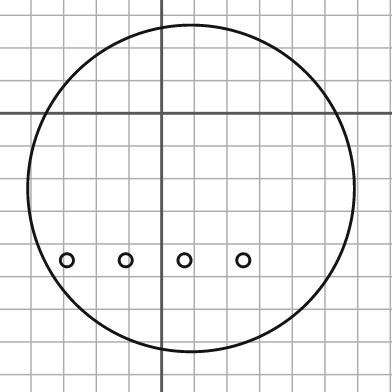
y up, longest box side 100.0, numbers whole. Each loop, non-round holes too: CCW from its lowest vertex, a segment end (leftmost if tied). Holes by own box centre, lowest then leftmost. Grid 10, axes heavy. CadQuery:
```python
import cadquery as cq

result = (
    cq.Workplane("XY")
    .moveTo(9.0, -23.0)
    .circle(50.0)
    .moveTo(-29.0, -45.0)
    .circle(2.0)
    .moveTo(-11.0, -45.0)
    .circle(2.0)
    .moveTo(7.0, -45.0)
    .circle(2.0)
    .moveTo(25.0, -45.0)
    .circle(2.0)
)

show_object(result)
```